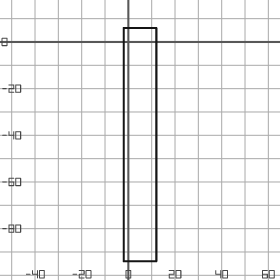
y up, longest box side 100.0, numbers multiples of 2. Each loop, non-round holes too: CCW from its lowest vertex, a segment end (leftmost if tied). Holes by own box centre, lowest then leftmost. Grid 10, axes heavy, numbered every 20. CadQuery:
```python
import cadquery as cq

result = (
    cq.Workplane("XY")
    .moveTo(-2.0, -94.0)
    .lineTo(12.0, -94.0)
    .lineTo(12.0, 6.0)
    .lineTo(-2.0, 6.0)
    .close()
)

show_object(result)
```